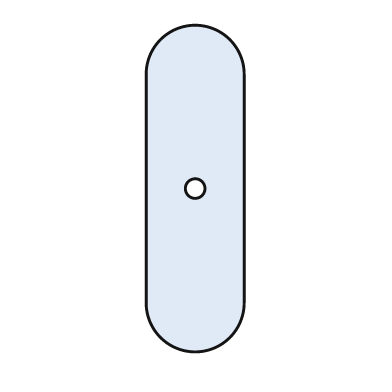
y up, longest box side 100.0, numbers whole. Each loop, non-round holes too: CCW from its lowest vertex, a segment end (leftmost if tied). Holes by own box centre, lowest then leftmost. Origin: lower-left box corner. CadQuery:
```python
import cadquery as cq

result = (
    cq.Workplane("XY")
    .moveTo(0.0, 15.0)
    .threePointArc((15.0, 0.0), (30.0, 15.0))
    .lineTo(30.0, 85.0)
    .threePointArc((15.0, 100.0), (0.0, 85.0))
    .close()
    .moveTo(15.0, 50.0)
    .circle(3.0)
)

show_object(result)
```